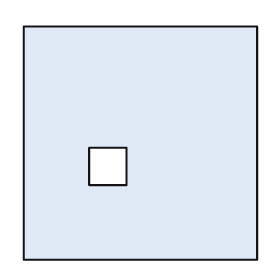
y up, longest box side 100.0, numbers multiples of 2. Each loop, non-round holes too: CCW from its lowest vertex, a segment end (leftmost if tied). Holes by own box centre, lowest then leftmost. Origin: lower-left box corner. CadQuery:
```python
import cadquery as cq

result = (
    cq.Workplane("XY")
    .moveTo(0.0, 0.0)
    .lineTo(100.0, 0.0)
    .lineTo(100.0, 100.0)
    .lineTo(0.0, 100.0)
    .close()
    .moveTo(28.0, 32.0)
    .lineTo(44.0, 32.0)
    .lineTo(44.0, 48.0)
    .lineTo(28.0, 48.0)
    .close()
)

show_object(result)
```